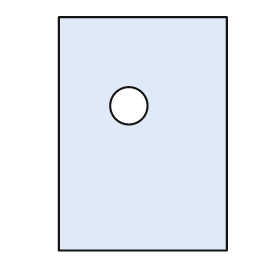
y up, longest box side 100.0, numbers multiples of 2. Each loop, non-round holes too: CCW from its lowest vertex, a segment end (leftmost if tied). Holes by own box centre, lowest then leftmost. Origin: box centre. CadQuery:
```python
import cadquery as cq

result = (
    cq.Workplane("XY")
    .moveTo(-36.0, -50.0)
    .lineTo(36.0, -50.0)
    .lineTo(36.0, 50.0)
    .lineTo(-36.0, 50.0)
    .close()
    .moveTo(-6.0, 12.0)
    .circle(8.0)
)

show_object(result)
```